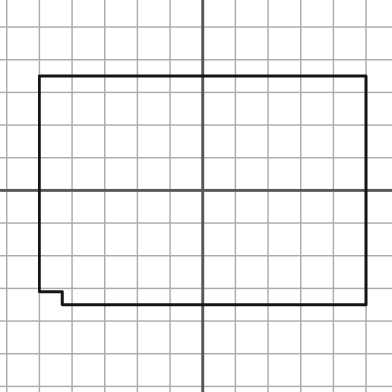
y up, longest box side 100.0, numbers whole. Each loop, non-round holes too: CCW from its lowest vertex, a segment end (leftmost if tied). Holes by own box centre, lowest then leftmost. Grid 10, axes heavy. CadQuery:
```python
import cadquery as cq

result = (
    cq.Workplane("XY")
    .moveTo(-43.0, -35.0)
    .lineTo(50.0, -35.0)
    .lineTo(50.0, 35.0)
    .lineTo(-50.0, 35.0)
    .lineTo(-50.0, -31.0)
    .lineTo(-43.0, -31.0)
    .close()
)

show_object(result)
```